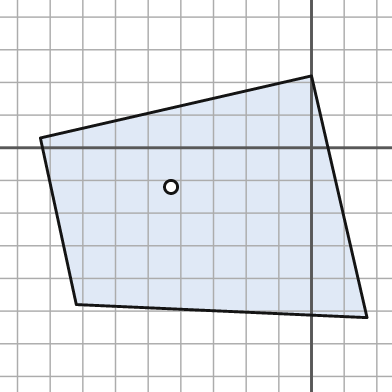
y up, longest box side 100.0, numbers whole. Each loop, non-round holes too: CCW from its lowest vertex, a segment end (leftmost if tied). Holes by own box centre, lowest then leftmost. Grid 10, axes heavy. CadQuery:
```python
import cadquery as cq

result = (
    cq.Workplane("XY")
    .moveTo(17.0, -52.0)
    .lineTo(0.0, 22.0)
    .lineTo(-83.0, 3.0)
    .lineTo(-72.0, -48.0)
    .close()
    .moveTo(-43.0, -12.0)
    .circle(2.0)
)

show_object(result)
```